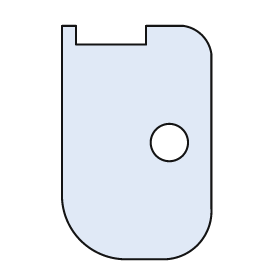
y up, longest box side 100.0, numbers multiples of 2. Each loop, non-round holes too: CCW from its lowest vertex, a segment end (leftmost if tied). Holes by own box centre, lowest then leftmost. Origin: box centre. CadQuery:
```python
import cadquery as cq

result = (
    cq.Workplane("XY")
    .moveTo(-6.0, -50.0)
    .lineTo(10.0, -50.0)
    .threePointArc((26.0, -44.0), (32.0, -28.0))
    .lineTo(32.0, 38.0)
    .threePointArc((28.0, 46.0), (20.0, 50.0))
    .lineTo(4.0, 50.0)
    .lineTo(4.0, 42.0)
    .lineTo(-26.0, 42.0)
    .lineTo(-26.0, 50.0)
    .lineTo(-32.0, 50.0)
    .lineTo(-32.0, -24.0)
    .threePointArc((-24.0, -42.0), (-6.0, -50.0))
    .close()
    .moveTo(14.0, 0.0)
    .circle(8.0)
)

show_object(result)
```